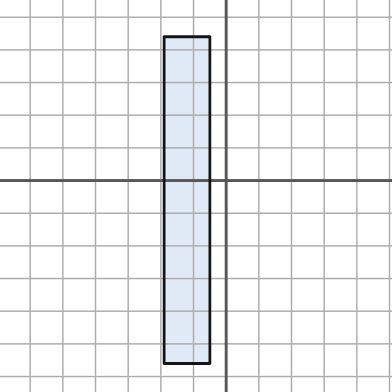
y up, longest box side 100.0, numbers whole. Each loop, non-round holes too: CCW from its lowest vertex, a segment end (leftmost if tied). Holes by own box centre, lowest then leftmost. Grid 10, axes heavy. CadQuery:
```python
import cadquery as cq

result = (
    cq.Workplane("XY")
    .moveTo(-19.0, -56.0)
    .lineTo(-5.0, -56.0)
    .lineTo(-5.0, 44.0)
    .lineTo(-19.0, 44.0)
    .close()
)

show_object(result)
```